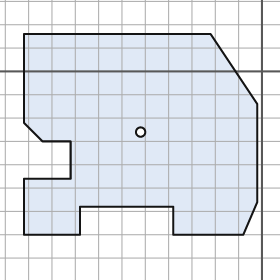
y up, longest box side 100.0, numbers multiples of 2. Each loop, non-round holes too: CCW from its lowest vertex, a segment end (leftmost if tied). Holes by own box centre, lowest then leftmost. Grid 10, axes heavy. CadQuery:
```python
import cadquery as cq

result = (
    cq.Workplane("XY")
    .moveTo(-102.0, -70.0)
    .lineTo(-78.0, -70.0)
    .lineTo(-78.0, -58.0)
    .lineTo(-38.0, -58.0)
    .lineTo(-38.0, -70.0)
    .lineTo(-8.0, -70.0)
    .lineTo(-2.0, -56.0)
    .lineTo(-2.0, -14.0)
    .lineTo(-22.0, 16.0)
    .lineTo(-102.0, 16.0)
    .lineTo(-102.0, -22.0)
    .lineTo(-94.0, -30.0)
    .lineTo(-82.0, -30.0)
    .lineTo(-82.0, -46.0)
    .lineTo(-102.0, -46.0)
    .close()
    .moveTo(-52.0, -26.0)
    .circle(2.0)
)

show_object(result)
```